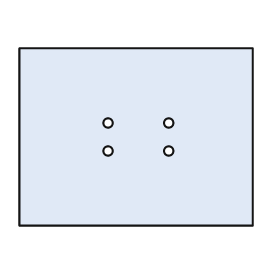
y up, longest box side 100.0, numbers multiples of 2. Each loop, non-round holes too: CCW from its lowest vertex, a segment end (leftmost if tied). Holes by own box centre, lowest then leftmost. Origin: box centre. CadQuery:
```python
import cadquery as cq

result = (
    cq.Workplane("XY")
    .moveTo(-50.0, -38.0)
    .lineTo(50.0, -38.0)
    .lineTo(50.0, 38.0)
    .lineTo(-50.0, 38.0)
    .close()
    .moveTo(-12.0, -6.0)
    .circle(2.0)
    .moveTo(14.0, -6.0)
    .circle(2.0)
    .moveTo(-12.0, 6.0)
    .circle(2.0)
    .moveTo(14.0, 6.0)
    .circle(2.0)
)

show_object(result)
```